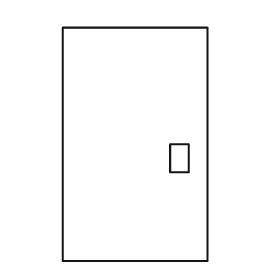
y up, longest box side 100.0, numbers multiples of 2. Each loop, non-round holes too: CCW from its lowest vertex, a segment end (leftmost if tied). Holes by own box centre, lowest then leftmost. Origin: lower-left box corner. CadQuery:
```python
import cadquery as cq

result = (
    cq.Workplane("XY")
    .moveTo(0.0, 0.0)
    .lineTo(62.0, 0.0)
    .lineTo(62.0, 100.0)
    .lineTo(0.0, 100.0)
    .close()
    .moveTo(46.0, 38.0)
    .lineTo(54.0, 38.0)
    .lineTo(54.0, 50.0)
    .lineTo(46.0, 50.0)
    .close()
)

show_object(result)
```